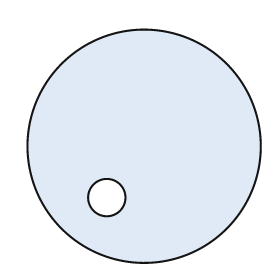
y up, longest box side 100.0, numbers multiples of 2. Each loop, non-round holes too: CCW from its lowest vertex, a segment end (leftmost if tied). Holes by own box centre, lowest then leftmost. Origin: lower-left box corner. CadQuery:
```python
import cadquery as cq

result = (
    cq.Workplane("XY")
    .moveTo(50.0, 50.0)
    .circle(50.0)
    .moveTo(34.0, 28.0)
    .circle(8.0)
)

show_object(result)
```